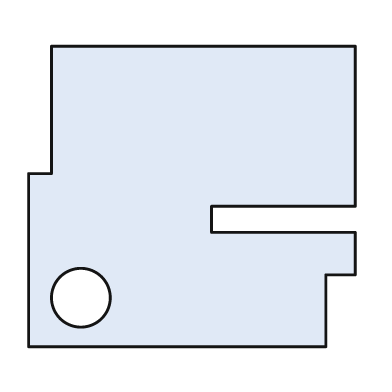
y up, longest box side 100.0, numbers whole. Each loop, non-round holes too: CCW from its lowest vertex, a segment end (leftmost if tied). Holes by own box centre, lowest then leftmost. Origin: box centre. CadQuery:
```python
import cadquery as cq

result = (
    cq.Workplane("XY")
    .moveTo(-50.0, -46.0)
    .lineTo(41.0, -46.0)
    .lineTo(41.0, -24.0)
    .lineTo(50.0, -24.0)
    .lineTo(50.0, -11.0)
    .lineTo(6.0, -11.0)
    .lineTo(6.0, -3.0)
    .lineTo(50.0, -3.0)
    .lineTo(50.0, 46.0)
    .lineTo(-43.0, 46.0)
    .lineTo(-43.0, 7.0)
    .lineTo(-50.0, 7.0)
    .close()
    .moveTo(-34.0, -31.0)
    .circle(9.0)
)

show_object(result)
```